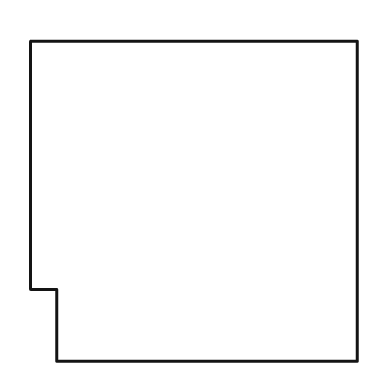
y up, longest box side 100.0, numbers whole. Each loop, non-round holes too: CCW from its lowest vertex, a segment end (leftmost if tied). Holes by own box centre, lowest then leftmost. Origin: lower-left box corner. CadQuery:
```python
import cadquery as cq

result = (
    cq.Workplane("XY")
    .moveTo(8.0, 0.0)
    .lineTo(100.0, 0.0)
    .lineTo(100.0, 98.0)
    .lineTo(0.0, 98.0)
    .lineTo(0.0, 22.0)
    .lineTo(8.0, 22.0)
    .close()
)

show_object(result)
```